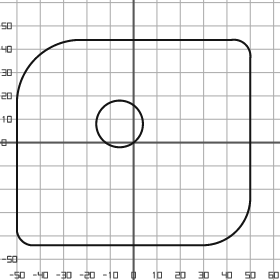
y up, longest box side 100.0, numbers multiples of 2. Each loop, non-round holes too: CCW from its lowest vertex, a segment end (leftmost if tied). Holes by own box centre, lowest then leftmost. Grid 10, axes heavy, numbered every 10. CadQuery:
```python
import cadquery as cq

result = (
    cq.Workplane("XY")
    .moveTo(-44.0, -44.0)
    .lineTo(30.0, -44.0)
    .threePointArc((44.0, -38.0), (50.0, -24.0))
    .lineTo(50.0, 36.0)
    .threePointArc((48.0, 42.0), (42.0, 44.0))
    .lineTo(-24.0, 44.0)
    .threePointArc((-42.0, 36.0), (-50.0, 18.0))
    .lineTo(-50.0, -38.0)
    .threePointArc((-48.0, -42.0), (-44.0, -44.0))
    .close()
    .moveTo(-6.0, 8.0)
    .circle(10.0)
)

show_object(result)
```